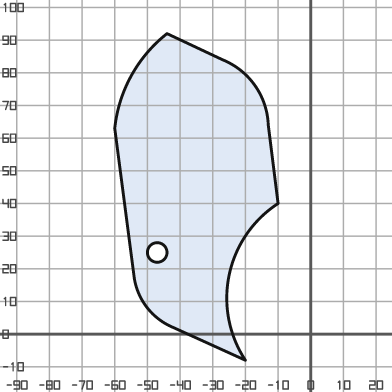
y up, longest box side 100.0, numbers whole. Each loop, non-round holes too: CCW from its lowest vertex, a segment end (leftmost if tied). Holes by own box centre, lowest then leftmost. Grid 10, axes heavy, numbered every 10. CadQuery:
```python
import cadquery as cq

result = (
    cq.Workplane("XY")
    .moveTo(-20.0, -8.0)
    .threePointArc((-25.0, 18.0), (-10.0, 40.0))
    .lineTo(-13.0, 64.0)
    .threePointArc((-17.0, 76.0), (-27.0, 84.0))
    .lineTo(-44.0, 92.0)
    .threePointArc((-55.0, 79.0), (-60.0, 63.0))
    .lineTo(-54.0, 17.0)
    .threePointArc((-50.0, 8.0), (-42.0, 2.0))
    .close()
    .moveTo(-47.0, 25.0)
    .circle(3.0)
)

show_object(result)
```